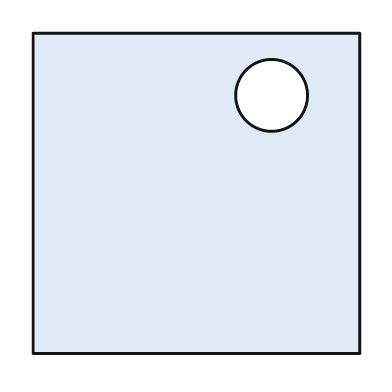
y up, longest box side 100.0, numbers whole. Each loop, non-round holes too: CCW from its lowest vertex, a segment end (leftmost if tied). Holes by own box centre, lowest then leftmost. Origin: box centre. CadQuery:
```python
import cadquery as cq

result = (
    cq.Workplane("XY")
    .moveTo(-50.0, -49.0)
    .lineTo(50.0, -49.0)
    .lineTo(50.0, 49.0)
    .lineTo(-50.0, 49.0)
    .close()
    .moveTo(23.0, 30.0)
    .circle(11.0)
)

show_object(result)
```